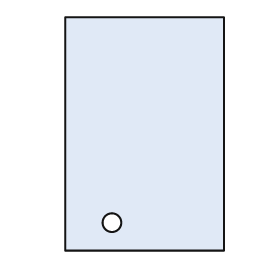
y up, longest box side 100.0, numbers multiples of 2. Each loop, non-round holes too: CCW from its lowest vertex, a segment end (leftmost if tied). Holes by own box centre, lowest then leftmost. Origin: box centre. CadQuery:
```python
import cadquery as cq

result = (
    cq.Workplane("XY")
    .moveTo(-34.0, -50.0)
    .lineTo(34.0, -50.0)
    .lineTo(34.0, 50.0)
    .lineTo(-34.0, 50.0)
    .close()
    .moveTo(-14.0, -38.0)
    .circle(4.0)
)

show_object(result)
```